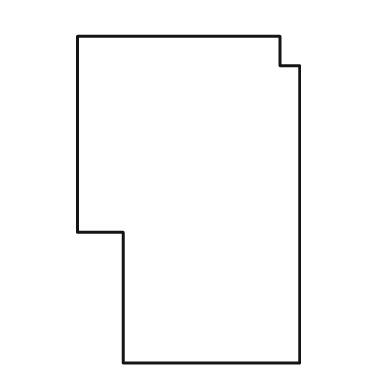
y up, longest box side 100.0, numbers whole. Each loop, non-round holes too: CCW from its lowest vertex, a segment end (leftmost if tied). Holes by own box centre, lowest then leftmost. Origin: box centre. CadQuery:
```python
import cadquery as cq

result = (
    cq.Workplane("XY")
    .moveTo(-20.0, -50.0)
    .lineTo(34.0, -50.0)
    .lineTo(34.0, 41.0)
    .lineTo(28.0, 41.0)
    .lineTo(28.0, 50.0)
    .lineTo(-34.0, 50.0)
    .lineTo(-34.0, -10.0)
    .lineTo(-20.0, -10.0)
    .close()
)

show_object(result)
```